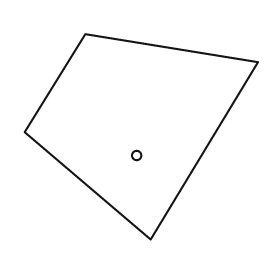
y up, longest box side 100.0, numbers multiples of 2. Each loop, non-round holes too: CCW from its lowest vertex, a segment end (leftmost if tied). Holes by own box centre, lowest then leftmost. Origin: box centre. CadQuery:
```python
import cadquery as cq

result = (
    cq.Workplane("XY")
    .moveTo(4.0, -44.0)
    .lineTo(50.0, 32.0)
    .lineTo(-24.0, 44.0)
    .lineTo(-50.0, 2.0)
    .close()
    .moveTo(-2.0, -8.0)
    .circle(2.0)
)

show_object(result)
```